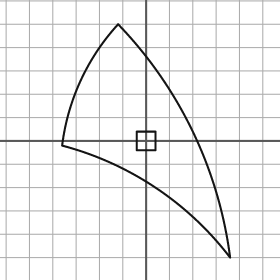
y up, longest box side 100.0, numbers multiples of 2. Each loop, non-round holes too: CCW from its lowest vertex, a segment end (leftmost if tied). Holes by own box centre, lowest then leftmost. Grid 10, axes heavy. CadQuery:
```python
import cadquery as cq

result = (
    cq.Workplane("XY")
    .moveTo(36.0, -50.0)
    .threePointArc((20.0, 4.0), (-12.0, 50.0))
    .threePointArc((-28.0, 26.0), (-36.0, -2.0))
    .threePointArc((4.0, -20.0), (36.0, -50.0))
    .close()
    .moveTo(-4.0, -4.0)
    .lineTo(4.0, -4.0)
    .lineTo(4.0, 4.0)
    .lineTo(-4.0, 4.0)
    .close()
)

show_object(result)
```